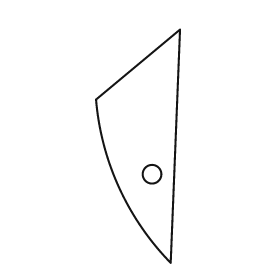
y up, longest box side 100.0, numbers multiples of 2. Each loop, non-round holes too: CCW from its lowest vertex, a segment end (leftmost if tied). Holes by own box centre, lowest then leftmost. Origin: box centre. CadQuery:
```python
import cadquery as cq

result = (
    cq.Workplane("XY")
    .moveTo(14.0, -50.0)
    .lineTo(18.0, 50.0)
    .lineTo(-18.0, 20.0)
    .threePointArc((-8.0, -18.0), (14.0, -50.0))
    .close()
    .moveTo(6.0, -12.0)
    .circle(4.0)
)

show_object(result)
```